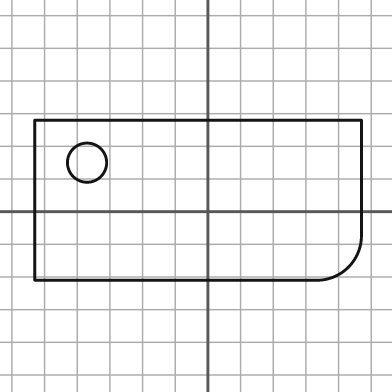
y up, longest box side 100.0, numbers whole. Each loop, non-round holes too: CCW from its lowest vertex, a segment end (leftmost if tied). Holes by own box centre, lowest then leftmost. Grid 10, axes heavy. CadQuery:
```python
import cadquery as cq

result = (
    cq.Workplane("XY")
    .moveTo(-53.0, -21.0)
    .lineTo(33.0, -21.0)
    .threePointArc((43.0, -17.0), (47.0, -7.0))
    .lineTo(47.0, 28.0)
    .lineTo(-53.0, 28.0)
    .close()
    .moveTo(-37.0, 15.0)
    .circle(6.0)
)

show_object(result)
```